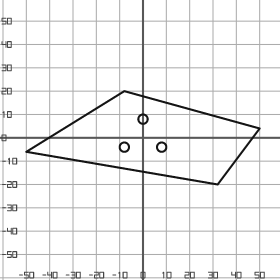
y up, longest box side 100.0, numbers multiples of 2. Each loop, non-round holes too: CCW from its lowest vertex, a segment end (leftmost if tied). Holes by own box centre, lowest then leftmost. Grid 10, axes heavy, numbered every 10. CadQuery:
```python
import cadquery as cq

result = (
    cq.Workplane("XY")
    .moveTo(32.0, -20.0)
    .lineTo(50.0, 4.0)
    .lineTo(-8.0, 20.0)
    .lineTo(-50.0, -6.0)
    .close()
    .moveTo(-8.0, -4.0)
    .circle(2.0)
    .moveTo(8.0, -4.0)
    .circle(2.0)
    .moveTo(0.0, 8.0)
    .circle(2.0)
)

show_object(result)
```